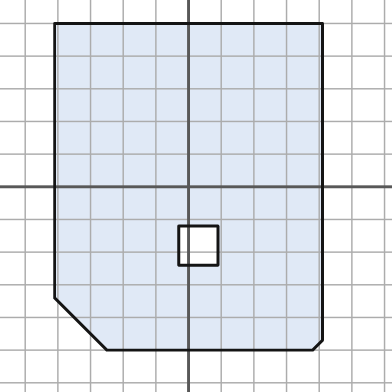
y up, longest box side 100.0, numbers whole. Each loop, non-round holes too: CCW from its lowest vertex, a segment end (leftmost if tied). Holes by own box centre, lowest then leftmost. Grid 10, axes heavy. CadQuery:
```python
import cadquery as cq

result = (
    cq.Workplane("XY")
    .moveTo(-25.0, -50.0)
    .lineTo(38.0, -50.0)
    .lineTo(41.0, -47.0)
    .lineTo(41.0, 50.0)
    .lineTo(-41.0, 50.0)
    .lineTo(-41.0, -34.0)
    .close()
    .moveTo(-3.0, -24.0)
    .lineTo(9.0, -24.0)
    .lineTo(9.0, -12.0)
    .lineTo(-3.0, -12.0)
    .close()
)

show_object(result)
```